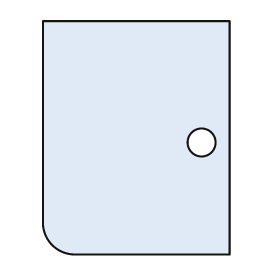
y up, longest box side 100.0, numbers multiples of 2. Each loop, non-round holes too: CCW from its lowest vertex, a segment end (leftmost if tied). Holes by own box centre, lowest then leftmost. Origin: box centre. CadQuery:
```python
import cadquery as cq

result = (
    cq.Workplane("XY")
    .moveTo(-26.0, -50.0)
    .lineTo(40.0, -50.0)
    .lineTo(40.0, 50.0)
    .lineTo(-40.0, 50.0)
    .lineTo(-40.0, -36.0)
    .threePointArc((-36.0, -46.0), (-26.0, -50.0))
    .close()
    .moveTo(28.0, -2.0)
    .circle(6.0)
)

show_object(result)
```